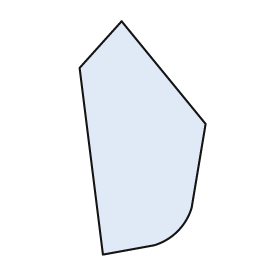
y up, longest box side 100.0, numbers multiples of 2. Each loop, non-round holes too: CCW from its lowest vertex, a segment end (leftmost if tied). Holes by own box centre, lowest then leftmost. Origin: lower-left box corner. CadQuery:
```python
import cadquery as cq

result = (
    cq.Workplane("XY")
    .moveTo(10.0, 0.0)
    .lineTo(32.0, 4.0)
    .threePointArc((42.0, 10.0), (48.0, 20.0))
    .lineTo(54.0, 56.0)
    .lineTo(18.0, 100.0)
    .lineTo(0.0, 80.0)
    .close()
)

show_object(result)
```